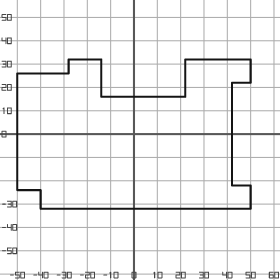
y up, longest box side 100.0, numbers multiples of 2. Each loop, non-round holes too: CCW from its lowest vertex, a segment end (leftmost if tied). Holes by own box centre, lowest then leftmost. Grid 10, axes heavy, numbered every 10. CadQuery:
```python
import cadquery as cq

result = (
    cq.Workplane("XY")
    .moveTo(-40.0, -32.0)
    .lineTo(50.0, -32.0)
    .lineTo(50.0, -22.0)
    .lineTo(42.0, -22.0)
    .lineTo(42.0, 22.0)
    .lineTo(50.0, 22.0)
    .lineTo(50.0, 32.0)
    .lineTo(22.0, 32.0)
    .lineTo(22.0, 16.0)
    .lineTo(-14.0, 16.0)
    .lineTo(-14.0, 32.0)
    .lineTo(-28.0, 32.0)
    .lineTo(-28.0, 26.0)
    .lineTo(-50.0, 26.0)
    .lineTo(-50.0, -24.0)
    .lineTo(-40.0, -24.0)
    .close()
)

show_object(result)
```